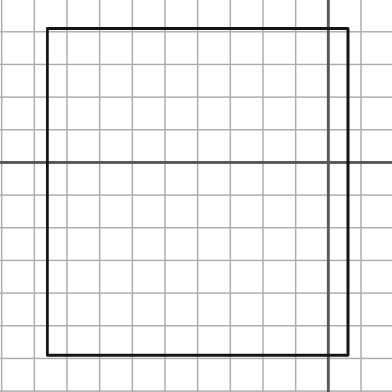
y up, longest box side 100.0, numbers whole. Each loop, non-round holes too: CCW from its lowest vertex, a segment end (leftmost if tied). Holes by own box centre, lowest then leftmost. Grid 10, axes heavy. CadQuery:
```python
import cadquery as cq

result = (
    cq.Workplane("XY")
    .moveTo(-86.0, -59.0)
    .lineTo(6.0, -59.0)
    .lineTo(6.0, 41.0)
    .lineTo(-86.0, 41.0)
    .close()
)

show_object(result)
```